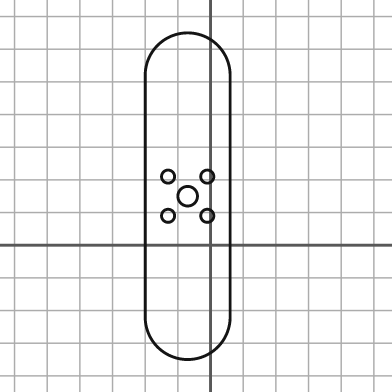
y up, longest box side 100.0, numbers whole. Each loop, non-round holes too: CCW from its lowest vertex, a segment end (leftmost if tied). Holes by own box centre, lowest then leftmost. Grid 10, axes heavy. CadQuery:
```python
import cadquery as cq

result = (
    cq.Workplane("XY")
    .moveTo(-20.0, -22.0)
    .threePointArc((-7.0, -35.0), (6.0, -22.0))
    .lineTo(6.0, 52.0)
    .threePointArc((-7.0, 65.0), (-20.0, 52.0))
    .close()
    .moveTo(-13.0, 9.0)
    .circle(2.0)
    .moveTo(-1.0, 9.0)
    .circle(2.0)
    .moveTo(-7.0, 15.0)
    .circle(3.0)
    .moveTo(-13.0, 21.0)
    .circle(2.0)
    .moveTo(-1.0, 21.0)
    .circle(2.0)
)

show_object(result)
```